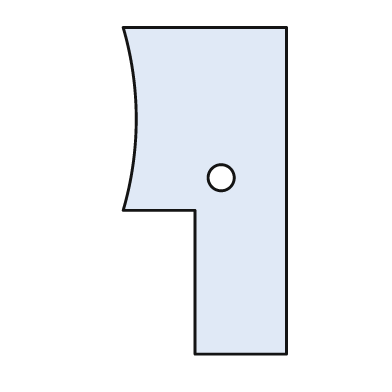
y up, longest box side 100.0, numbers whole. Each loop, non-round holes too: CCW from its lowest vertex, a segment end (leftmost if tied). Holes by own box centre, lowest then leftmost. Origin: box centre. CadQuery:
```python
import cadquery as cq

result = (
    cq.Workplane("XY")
    .moveTo(-3.0, -50.0)
    .lineTo(25.0, -50.0)
    .lineTo(25.0, 50.0)
    .lineTo(-25.0, 50.0)
    .threePointArc((-21.0, 22.0), (-25.0, -6.0))
    .lineTo(-3.0, -6.0)
    .close()
    .moveTo(5.0, 4.0)
    .circle(4.0)
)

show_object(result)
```